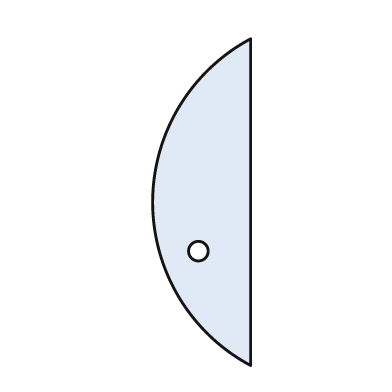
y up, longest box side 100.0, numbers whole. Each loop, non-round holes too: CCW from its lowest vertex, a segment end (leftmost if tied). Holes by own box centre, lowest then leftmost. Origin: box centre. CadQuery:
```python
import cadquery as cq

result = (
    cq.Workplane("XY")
    .moveTo(15.0, -50.0)
    .lineTo(15.0, 50.0)
    .threePointArc((-15.0, 0.0), (15.0, -50.0))
    .close()
    .moveTo(-1.0, -15.0)
    .circle(3.0)
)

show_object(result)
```